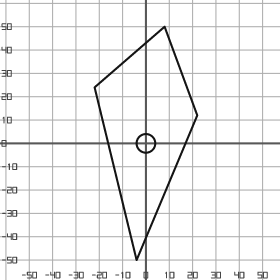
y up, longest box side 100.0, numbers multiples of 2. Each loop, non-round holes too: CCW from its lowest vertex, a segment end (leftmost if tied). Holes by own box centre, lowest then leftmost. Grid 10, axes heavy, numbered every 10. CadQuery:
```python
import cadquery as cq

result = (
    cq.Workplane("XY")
    .moveTo(-4.0, -50.0)
    .lineTo(22.0, 12.0)
    .lineTo(8.0, 50.0)
    .lineTo(-22.0, 24.0)
    .close()
    .moveTo(0.0, 0.0)
    .circle(4.0)
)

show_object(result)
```